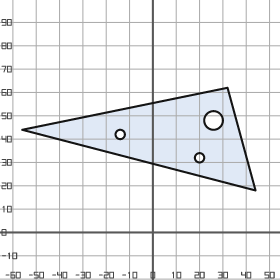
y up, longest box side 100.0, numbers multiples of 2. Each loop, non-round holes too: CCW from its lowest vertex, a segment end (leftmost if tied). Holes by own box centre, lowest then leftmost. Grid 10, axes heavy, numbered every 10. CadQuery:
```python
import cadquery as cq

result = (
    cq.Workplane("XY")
    .moveTo(44.0, 18.0)
    .lineTo(32.0, 62.0)
    .lineTo(-56.0, 44.0)
    .close()
    .moveTo(20.0, 32.0)
    .circle(2.0)
    .moveTo(-14.0, 42.0)
    .circle(2.0)
    .moveTo(26.0, 48.0)
    .circle(4.0)
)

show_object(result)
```